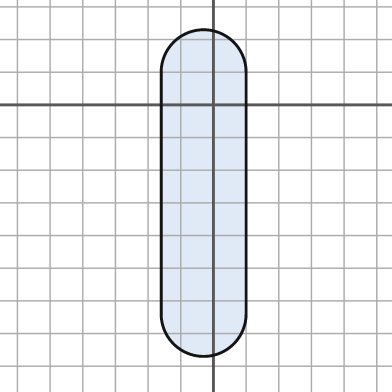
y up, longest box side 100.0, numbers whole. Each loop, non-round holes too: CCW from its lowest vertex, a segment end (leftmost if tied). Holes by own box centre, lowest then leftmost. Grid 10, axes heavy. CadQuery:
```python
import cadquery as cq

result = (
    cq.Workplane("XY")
    .moveTo(-16.0, -64.0)
    .threePointArc((-3.0, -77.0), (10.0, -64.0))
    .lineTo(10.0, 10.0)
    .threePointArc((-3.0, 23.0), (-16.0, 10.0))
    .close()
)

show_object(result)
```